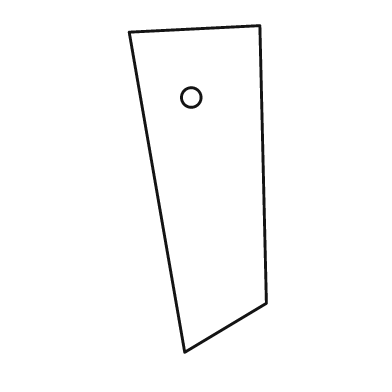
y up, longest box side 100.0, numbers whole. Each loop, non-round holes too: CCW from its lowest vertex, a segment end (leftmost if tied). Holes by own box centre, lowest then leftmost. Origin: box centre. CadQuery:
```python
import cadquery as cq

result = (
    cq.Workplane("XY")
    .moveTo(-4.0, -50.0)
    .lineTo(21.0, -35.0)
    .lineTo(19.0, 50.0)
    .lineTo(-21.0, 48.0)
    .close()
    .moveTo(-2.0, 28.0)
    .circle(3.0)
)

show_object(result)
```